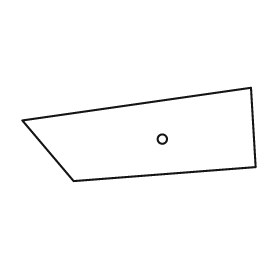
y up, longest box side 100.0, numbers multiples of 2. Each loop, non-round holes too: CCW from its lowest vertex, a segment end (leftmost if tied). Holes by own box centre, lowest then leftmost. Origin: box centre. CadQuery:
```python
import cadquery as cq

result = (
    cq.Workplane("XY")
    .moveTo(-28.0, -20.0)
    .lineTo(50.0, -14.0)
    .lineTo(48.0, 20.0)
    .lineTo(-50.0, 6.0)
    .close()
    .moveTo(10.0, -2.0)
    .circle(2.0)
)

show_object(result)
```